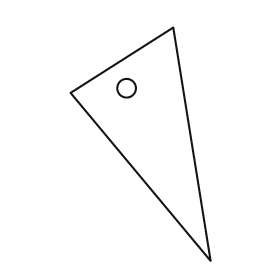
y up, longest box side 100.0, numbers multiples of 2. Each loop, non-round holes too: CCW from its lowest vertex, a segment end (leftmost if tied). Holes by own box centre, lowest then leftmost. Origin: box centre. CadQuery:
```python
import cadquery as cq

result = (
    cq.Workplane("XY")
    .moveTo(30.0, -50.0)
    .lineTo(14.0, 50.0)
    .lineTo(-30.0, 22.0)
    .close()
    .moveTo(-6.0, 24.0)
    .circle(4.0)
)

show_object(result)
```